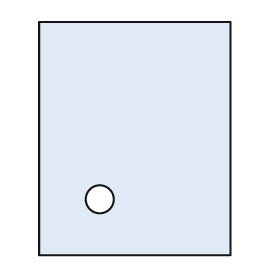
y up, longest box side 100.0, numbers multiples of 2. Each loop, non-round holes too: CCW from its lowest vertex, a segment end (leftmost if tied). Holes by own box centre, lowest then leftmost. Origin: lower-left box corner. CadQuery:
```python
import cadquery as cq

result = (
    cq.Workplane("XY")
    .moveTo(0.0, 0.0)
    .lineTo(82.0, 0.0)
    .lineTo(82.0, 100.0)
    .lineTo(0.0, 100.0)
    .close()
    .moveTo(26.0, 24.0)
    .circle(6.0)
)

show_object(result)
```